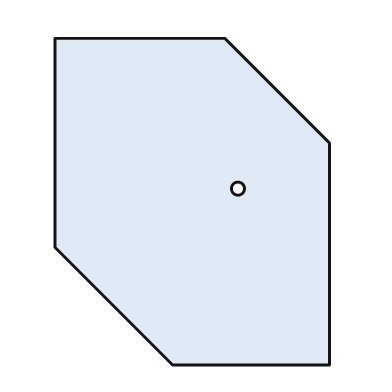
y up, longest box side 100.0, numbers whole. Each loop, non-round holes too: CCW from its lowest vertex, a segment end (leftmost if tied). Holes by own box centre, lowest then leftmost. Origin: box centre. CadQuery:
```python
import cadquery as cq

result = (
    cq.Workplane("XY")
    .moveTo(-6.0, -50.0)
    .lineTo(42.0, -50.0)
    .lineTo(42.0, 18.0)
    .lineTo(10.0, 50.0)
    .lineTo(-42.0, 50.0)
    .lineTo(-42.0, -14.0)
    .close()
    .moveTo(14.0, 4.0)
    .circle(2.0)
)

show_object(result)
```